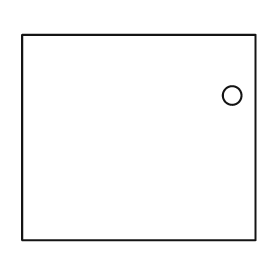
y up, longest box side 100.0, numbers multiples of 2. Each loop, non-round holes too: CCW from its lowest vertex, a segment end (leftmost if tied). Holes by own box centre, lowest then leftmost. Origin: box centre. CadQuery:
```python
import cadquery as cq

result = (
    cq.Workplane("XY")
    .moveTo(-50.0, -44.0)
    .lineTo(50.0, -44.0)
    .lineTo(50.0, 44.0)
    .lineTo(-50.0, 44.0)
    .close()
    .moveTo(40.0, 18.0)
    .circle(4.0)
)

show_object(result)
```